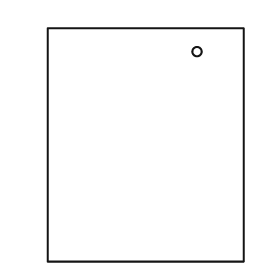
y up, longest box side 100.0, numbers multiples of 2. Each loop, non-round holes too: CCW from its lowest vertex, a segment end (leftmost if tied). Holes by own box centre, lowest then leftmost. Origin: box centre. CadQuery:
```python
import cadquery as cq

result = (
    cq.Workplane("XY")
    .moveTo(-42.0, -50.0)
    .lineTo(42.0, -50.0)
    .lineTo(42.0, 50.0)
    .lineTo(-42.0, 50.0)
    .close()
    .moveTo(22.0, 40.0)
    .circle(2.0)
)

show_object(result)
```